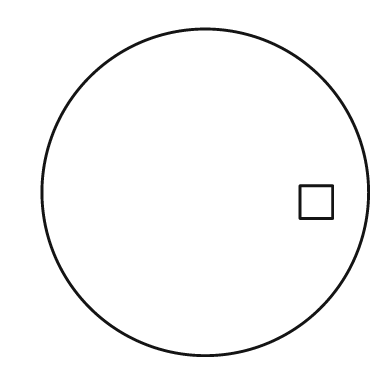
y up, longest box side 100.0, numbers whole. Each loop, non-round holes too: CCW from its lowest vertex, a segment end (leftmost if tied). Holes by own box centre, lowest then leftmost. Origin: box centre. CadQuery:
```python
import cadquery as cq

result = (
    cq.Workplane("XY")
    .moveTo(0.0, 0.0)
    .circle(50.0)
    .moveTo(29.0, -8.0)
    .lineTo(39.0, -8.0)
    .lineTo(39.0, 2.0)
    .lineTo(29.0, 2.0)
    .close()
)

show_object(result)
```